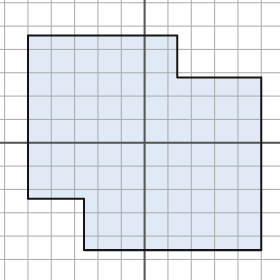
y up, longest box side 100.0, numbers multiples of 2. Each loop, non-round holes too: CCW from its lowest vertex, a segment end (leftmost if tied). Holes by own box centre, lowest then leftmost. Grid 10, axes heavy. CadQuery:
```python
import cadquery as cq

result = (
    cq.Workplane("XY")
    .moveTo(-26.0, -46.0)
    .lineTo(50.0, -46.0)
    .lineTo(50.0, 28.0)
    .lineTo(14.0, 28.0)
    .lineTo(14.0, 46.0)
    .lineTo(-50.0, 46.0)
    .lineTo(-50.0, -24.0)
    .lineTo(-26.0, -24.0)
    .close()
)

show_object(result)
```